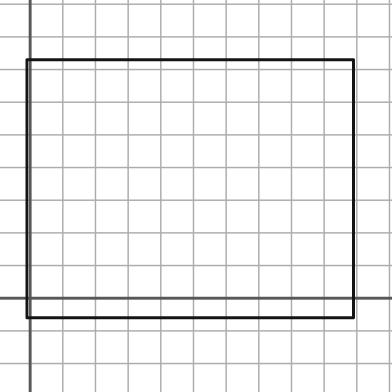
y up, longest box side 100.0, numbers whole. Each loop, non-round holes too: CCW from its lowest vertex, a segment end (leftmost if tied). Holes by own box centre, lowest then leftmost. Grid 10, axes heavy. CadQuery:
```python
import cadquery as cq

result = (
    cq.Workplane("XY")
    .moveTo(-1.0, -6.0)
    .lineTo(99.0, -6.0)
    .lineTo(99.0, 73.0)
    .lineTo(-1.0, 73.0)
    .close()
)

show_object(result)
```